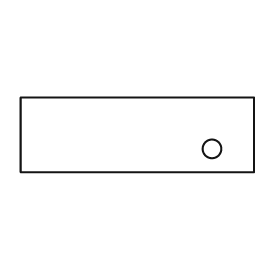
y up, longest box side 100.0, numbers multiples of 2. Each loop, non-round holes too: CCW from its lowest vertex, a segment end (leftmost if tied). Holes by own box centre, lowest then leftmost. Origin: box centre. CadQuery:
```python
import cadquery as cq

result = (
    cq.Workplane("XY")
    .moveTo(-50.0, -16.0)
    .lineTo(50.0, -16.0)
    .lineTo(50.0, 16.0)
    .lineTo(-50.0, 16.0)
    .close()
    .moveTo(32.0, -6.0)
    .circle(4.0)
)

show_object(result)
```